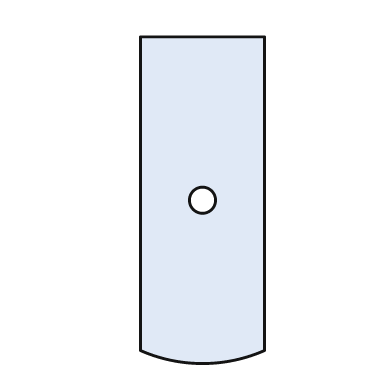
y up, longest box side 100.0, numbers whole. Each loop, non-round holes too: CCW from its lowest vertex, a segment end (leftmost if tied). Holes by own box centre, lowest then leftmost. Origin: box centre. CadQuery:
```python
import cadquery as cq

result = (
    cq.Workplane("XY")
    .moveTo(-19.0, -46.0)
    .threePointArc((0.0, -50.0), (19.0, -46.0))
    .lineTo(19.0, 50.0)
    .lineTo(-19.0, 50.0)
    .close()
    .moveTo(0.0, 0.0)
    .circle(4.0)
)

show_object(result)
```